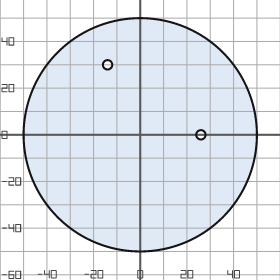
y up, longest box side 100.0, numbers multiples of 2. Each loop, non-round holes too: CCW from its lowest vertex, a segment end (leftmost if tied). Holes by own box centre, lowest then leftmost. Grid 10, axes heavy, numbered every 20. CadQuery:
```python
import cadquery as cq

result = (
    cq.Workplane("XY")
    .moveTo(0.0, 0.0)
    .circle(50.0)
    .moveTo(26.0, 0.0)
    .circle(2.0)
    .moveTo(-14.0, 30.0)
    .circle(2.0)
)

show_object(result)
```